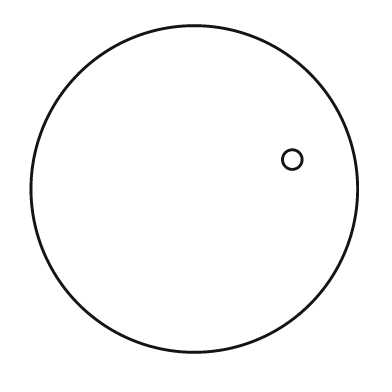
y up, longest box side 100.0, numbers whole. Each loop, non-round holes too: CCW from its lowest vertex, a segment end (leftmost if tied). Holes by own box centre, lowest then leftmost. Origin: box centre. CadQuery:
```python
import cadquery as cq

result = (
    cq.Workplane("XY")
    .moveTo(0.0, 0.0)
    .circle(50.0)
    .moveTo(30.0, 9.0)
    .circle(3.0)
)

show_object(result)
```